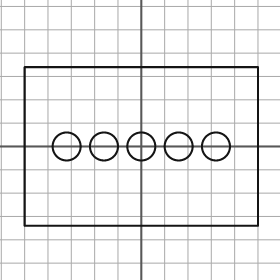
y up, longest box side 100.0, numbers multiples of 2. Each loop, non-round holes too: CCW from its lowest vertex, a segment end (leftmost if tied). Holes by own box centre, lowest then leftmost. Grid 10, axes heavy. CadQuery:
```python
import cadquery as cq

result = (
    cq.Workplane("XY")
    .moveTo(-50.0, -34.0)
    .lineTo(50.0, -34.0)
    .lineTo(50.0, 34.0)
    .lineTo(-50.0, 34.0)
    .close()
    .moveTo(-32.0, 0.0)
    .circle(6.0)
    .moveTo(-16.0, 0.0)
    .circle(6.0)
    .moveTo(0.0, 0.0)
    .circle(6.0)
    .moveTo(16.0, 0.0)
    .circle(6.0)
    .moveTo(32.0, 0.0)
    .circle(6.0)
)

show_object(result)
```